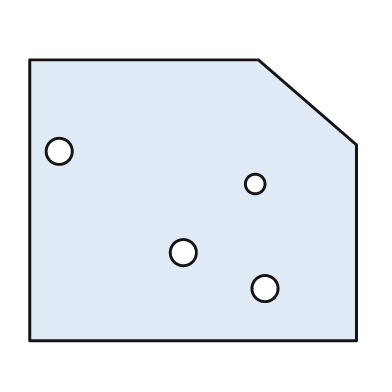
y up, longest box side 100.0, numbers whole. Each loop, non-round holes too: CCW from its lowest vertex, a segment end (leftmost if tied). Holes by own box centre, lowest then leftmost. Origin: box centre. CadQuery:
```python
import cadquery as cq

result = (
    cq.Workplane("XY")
    .moveTo(-50.0, -43.0)
    .lineTo(50.0, -43.0)
    .lineTo(50.0, 17.0)
    .lineTo(20.0, 43.0)
    .lineTo(-50.0, 43.0)
    .close()
    .moveTo(22.0, -27.0)
    .circle(4.0)
    .moveTo(-3.0, -16.0)
    .circle(4.0)
    .moveTo(19.0, 5.0)
    .circle(3.0)
    .moveTo(-41.0, 15.0)
    .circle(4.0)
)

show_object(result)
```